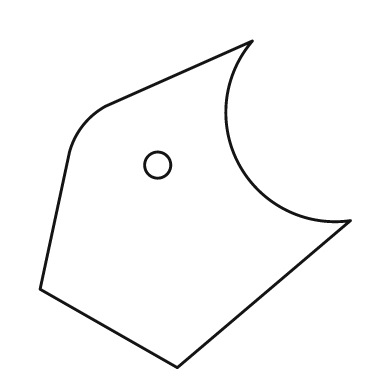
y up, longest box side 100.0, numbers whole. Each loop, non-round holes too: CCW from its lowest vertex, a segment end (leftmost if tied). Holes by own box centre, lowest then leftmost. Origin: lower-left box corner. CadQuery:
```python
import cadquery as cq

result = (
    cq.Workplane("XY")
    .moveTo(42.0, 0.0)
    .lineTo(95.0, 45.0)
    .threePointArc((61.0, 62.0), (65.0, 100.0))
    .lineTo(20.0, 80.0)
    .threePointArc((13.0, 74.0), (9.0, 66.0))
    .lineTo(0.0, 24.0)
    .close()
    .moveTo(36.0, 62.0)
    .circle(4.0)
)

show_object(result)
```